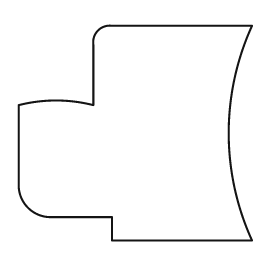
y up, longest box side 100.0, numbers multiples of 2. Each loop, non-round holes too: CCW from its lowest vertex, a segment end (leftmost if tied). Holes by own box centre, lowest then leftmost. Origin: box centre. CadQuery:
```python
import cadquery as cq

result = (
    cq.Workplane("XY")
    .moveTo(-10.0, -46.0)
    .lineTo(50.0, -46.0)
    .threePointArc((40.0, 0.0), (50.0, 46.0))
    .lineTo(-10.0, 46.0)
    .threePointArc((-16.0, 44.0), (-18.0, 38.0))
    .lineTo(-18.0, 12.0)
    .threePointArc((-34.0, 14.0), (-50.0, 12.0))
    .lineTo(-50.0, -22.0)
    .threePointArc((-46.0, -32.0), (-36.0, -36.0))
    .lineTo(-10.0, -36.0)
    .close()
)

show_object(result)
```